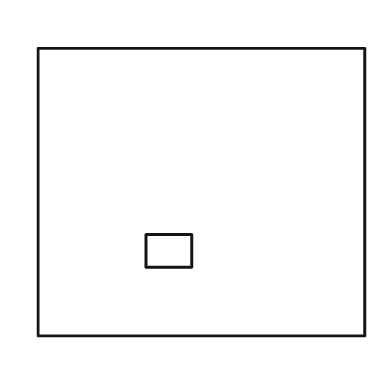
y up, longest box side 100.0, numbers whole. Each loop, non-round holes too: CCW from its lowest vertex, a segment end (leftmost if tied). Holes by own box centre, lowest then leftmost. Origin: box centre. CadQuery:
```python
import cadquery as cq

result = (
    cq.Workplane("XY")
    .moveTo(-50.0, -44.0)
    .lineTo(50.0, -44.0)
    .lineTo(50.0, 44.0)
    .lineTo(-50.0, 44.0)
    .close()
    .moveTo(-17.0, -23.0)
    .lineTo(-3.0, -23.0)
    .lineTo(-3.0, -13.0)
    .lineTo(-17.0, -13.0)
    .close()
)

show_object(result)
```